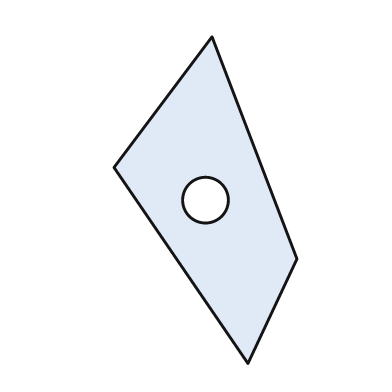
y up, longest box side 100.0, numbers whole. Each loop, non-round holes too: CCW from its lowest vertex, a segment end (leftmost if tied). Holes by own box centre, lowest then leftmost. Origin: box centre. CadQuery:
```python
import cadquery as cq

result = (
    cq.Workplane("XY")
    .moveTo(13.0, -50.0)
    .lineTo(28.0, -18.0)
    .lineTo(2.0, 50.0)
    .lineTo(-28.0, 10.0)
    .close()
    .moveTo(0.0, 0.0)
    .circle(7.0)
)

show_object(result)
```